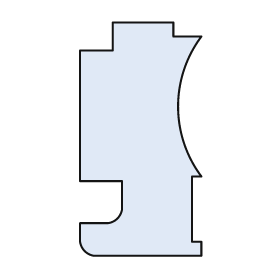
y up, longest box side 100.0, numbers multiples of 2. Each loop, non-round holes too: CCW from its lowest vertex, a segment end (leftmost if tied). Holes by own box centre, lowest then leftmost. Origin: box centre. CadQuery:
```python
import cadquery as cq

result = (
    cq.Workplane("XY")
    .moveTo(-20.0, -50.0)
    .lineTo(26.0, -50.0)
    .lineTo(26.0, -44.0)
    .lineTo(22.0, -44.0)
    .lineTo(22.0, -16.0)
    .lineTo(26.0, -16.0)
    .threePointArc((16.0, 14.0), (26.0, 44.0))
    .lineTo(14.0, 44.0)
    .lineTo(14.0, 50.0)
    .lineTo(-12.0, 50.0)
    .lineTo(-12.0, 38.0)
    .lineTo(-26.0, 38.0)
    .lineTo(-26.0, -18.0)
    .lineTo(-8.0, -18.0)
    .lineTo(-8.0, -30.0)
    .threePointArc((-10.0, -34.0), (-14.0, -36.0))
    .lineTo(-26.0, -36.0)
    .lineTo(-26.0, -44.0)
    .threePointArc((-24.0, -48.0), (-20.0, -50.0))
    .close()
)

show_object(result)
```